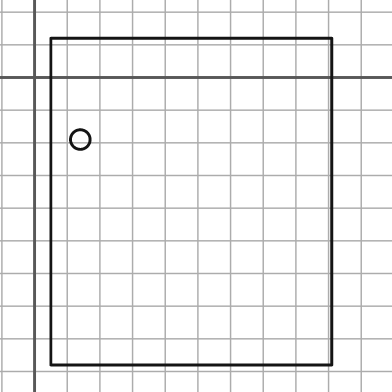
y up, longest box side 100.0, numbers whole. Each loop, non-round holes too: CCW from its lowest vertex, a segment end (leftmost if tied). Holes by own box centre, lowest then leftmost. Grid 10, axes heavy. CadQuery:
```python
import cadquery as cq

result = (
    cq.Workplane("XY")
    .moveTo(5.0, -88.0)
    .lineTo(91.0, -88.0)
    .lineTo(91.0, 12.0)
    .lineTo(5.0, 12.0)
    .close()
    .moveTo(14.0, -19.0)
    .circle(3.0)
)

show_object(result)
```